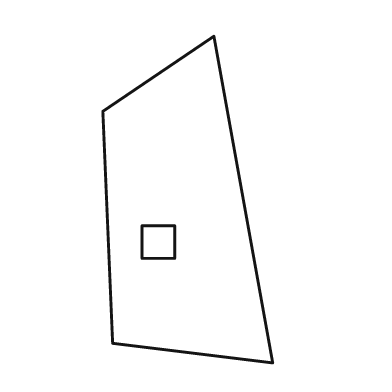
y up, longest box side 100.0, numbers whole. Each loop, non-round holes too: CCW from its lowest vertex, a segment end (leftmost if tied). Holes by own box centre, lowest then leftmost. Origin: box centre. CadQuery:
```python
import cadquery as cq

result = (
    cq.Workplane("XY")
    .moveTo(26.0, -50.0)
    .lineTo(8.0, 50.0)
    .lineTo(-26.0, 27.0)
    .lineTo(-23.0, -44.0)
    .close()
    .moveTo(-14.0, -18.0)
    .lineTo(-4.0, -18.0)
    .lineTo(-4.0, -8.0)
    .lineTo(-14.0, -8.0)
    .close()
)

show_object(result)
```